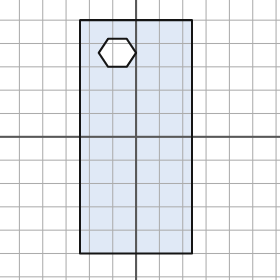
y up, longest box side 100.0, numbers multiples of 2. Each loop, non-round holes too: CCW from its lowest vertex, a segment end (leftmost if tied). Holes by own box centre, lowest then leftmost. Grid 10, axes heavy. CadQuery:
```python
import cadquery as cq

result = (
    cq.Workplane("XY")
    .moveTo(-24.0, -50.0)
    .lineTo(24.0, -50.0)
    .lineTo(24.0, 50.0)
    .lineTo(-24.0, 50.0)
    .close()
    .moveTo(-12.0, 30.0)
    .lineTo(-4.0, 30.0)
    .lineTo(0.0, 36.0)
    .lineTo(-4.0, 42.0)
    .lineTo(-12.0, 42.0)
    .lineTo(-16.0, 36.0)
    .close()
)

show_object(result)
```